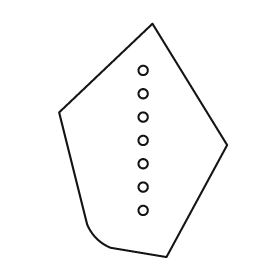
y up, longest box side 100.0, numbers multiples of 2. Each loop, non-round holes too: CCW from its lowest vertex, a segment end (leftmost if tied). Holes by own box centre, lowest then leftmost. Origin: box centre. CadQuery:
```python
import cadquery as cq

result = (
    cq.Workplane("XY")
    .moveTo(10.0, -50.0)
    .lineTo(36.0, -2.0)
    .lineTo(4.0, 50.0)
    .lineTo(-36.0, 12.0)
    .lineTo(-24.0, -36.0)
    .threePointArc((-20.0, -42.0), (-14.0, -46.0))
    .close()
    .moveTo(0.0, -30.0)
    .circle(2.0)
    .moveTo(0.0, -20.0)
    .circle(2.0)
    .moveTo(0.0, -10.0)
    .circle(2.0)
    .moveTo(0.0, 0.0)
    .circle(2.0)
    .moveTo(0.0, 10.0)
    .circle(2.0)
    .moveTo(0.0, 20.0)
    .circle(2.0)
    .moveTo(0.0, 30.0)
    .circle(2.0)
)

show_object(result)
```